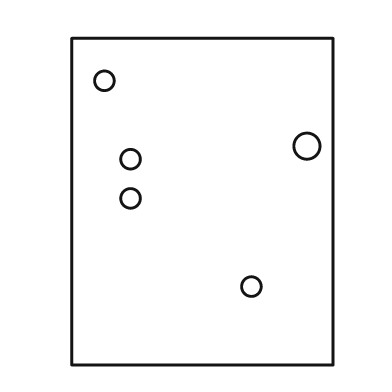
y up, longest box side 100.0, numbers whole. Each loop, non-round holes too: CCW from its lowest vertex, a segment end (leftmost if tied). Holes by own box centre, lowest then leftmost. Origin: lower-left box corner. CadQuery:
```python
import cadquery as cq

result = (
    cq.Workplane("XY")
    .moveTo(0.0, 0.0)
    .lineTo(80.0, 0.0)
    .lineTo(80.0, 100.0)
    .lineTo(0.0, 100.0)
    .close()
    .moveTo(55.0, 24.0)
    .circle(3.0)
    .moveTo(18.0, 51.0)
    .circle(3.0)
    .moveTo(18.0, 63.0)
    .circle(3.0)
    .moveTo(72.0, 67.0)
    .circle(4.0)
    .moveTo(10.0, 87.0)
    .circle(3.0)
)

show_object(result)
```